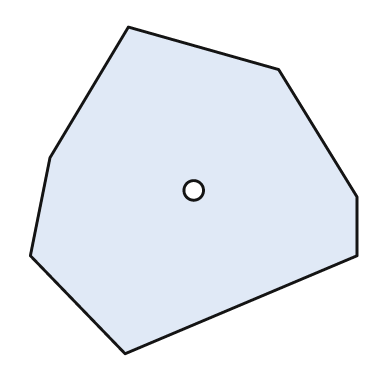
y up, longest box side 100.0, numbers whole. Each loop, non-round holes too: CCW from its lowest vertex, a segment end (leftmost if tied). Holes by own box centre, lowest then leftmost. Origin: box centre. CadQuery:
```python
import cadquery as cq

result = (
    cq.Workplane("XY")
    .moveTo(-21.0, -50.0)
    .lineTo(50.0, -20.0)
    .lineTo(50.0, -2.0)
    .lineTo(26.0, 37.0)
    .lineTo(-20.0, 50.0)
    .lineTo(-44.0, 10.0)
    .lineTo(-50.0, -20.0)
    .close()
    .moveTo(0.0, 0.0)
    .circle(3.0)
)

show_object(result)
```